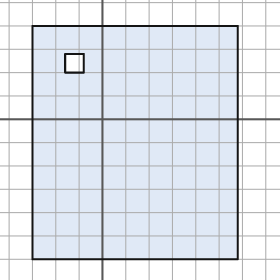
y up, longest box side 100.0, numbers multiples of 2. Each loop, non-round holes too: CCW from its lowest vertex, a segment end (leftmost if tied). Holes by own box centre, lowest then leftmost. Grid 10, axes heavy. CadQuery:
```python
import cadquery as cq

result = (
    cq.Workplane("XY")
    .moveTo(-30.0, -60.0)
    .lineTo(58.0, -60.0)
    .lineTo(58.0, 40.0)
    .lineTo(-30.0, 40.0)
    .close()
    .moveTo(-16.0, 20.0)
    .lineTo(-8.0, 20.0)
    .lineTo(-8.0, 28.0)
    .lineTo(-16.0, 28.0)
    .close()
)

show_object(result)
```